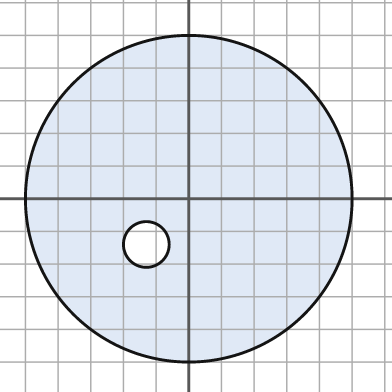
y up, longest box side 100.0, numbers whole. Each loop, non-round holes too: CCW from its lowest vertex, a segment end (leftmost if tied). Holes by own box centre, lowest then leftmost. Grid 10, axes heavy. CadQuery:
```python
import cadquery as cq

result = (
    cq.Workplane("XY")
    .moveTo(0.0, 0.0)
    .circle(50.0)
    .moveTo(-13.0, -14.0)
    .circle(7.0)
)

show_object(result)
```